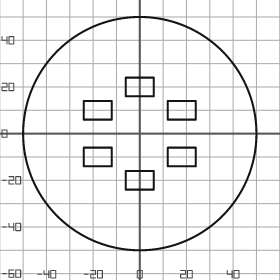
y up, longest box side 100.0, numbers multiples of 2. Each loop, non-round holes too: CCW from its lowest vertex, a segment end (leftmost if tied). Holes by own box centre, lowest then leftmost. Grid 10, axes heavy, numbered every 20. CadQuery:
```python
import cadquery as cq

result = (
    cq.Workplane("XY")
    .moveTo(0.0, 0.0)
    .circle(50.0)
    .moveTo(-6.0, -24.0)
    .lineTo(6.0, -24.0)
    .lineTo(6.0, -16.0)
    .lineTo(-6.0, -16.0)
    .close()
    .moveTo(-24.0, -14.0)
    .lineTo(-12.0, -14.0)
    .lineTo(-12.0, -6.0)
    .lineTo(-24.0, -6.0)
    .close()
    .moveTo(12.0, -14.0)
    .lineTo(24.0, -14.0)
    .lineTo(24.0, -6.0)
    .lineTo(12.0, -6.0)
    .close()
    .moveTo(-24.0, 6.0)
    .lineTo(-12.0, 6.0)
    .lineTo(-12.0, 14.0)
    .lineTo(-24.0, 14.0)
    .close()
    .moveTo(12.0, 6.0)
    .lineTo(24.0, 6.0)
    .lineTo(24.0, 14.0)
    .lineTo(12.0, 14.0)
    .close()
    .moveTo(-6.0, 16.0)
    .lineTo(6.0, 16.0)
    .lineTo(6.0, 24.0)
    .lineTo(-6.0, 24.0)
    .close()
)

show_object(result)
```